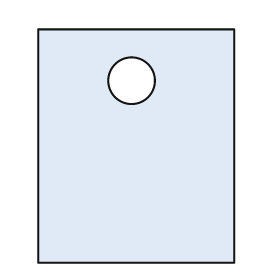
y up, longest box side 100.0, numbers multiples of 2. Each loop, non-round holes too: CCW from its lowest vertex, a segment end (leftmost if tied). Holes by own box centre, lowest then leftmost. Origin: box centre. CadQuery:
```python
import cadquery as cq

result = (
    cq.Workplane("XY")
    .moveTo(-42.0, -50.0)
    .lineTo(42.0, -50.0)
    .lineTo(42.0, 50.0)
    .lineTo(-42.0, 50.0)
    .close()
    .moveTo(-2.0, 28.0)
    .circle(10.0)
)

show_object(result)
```